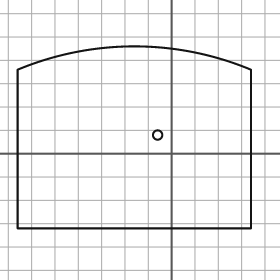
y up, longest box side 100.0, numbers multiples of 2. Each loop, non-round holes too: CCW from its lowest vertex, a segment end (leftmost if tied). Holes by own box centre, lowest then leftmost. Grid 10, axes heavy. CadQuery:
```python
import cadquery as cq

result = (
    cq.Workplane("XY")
    .moveTo(-66.0, -32.0)
    .lineTo(34.0, -32.0)
    .lineTo(34.0, 36.0)
    .threePointArc((-16.0, 46.0), (-66.0, 36.0))
    .close()
    .moveTo(-6.0, 8.0)
    .circle(2.0)
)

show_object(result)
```